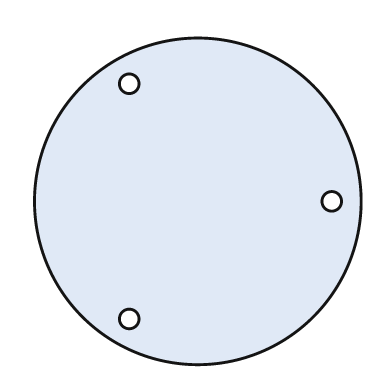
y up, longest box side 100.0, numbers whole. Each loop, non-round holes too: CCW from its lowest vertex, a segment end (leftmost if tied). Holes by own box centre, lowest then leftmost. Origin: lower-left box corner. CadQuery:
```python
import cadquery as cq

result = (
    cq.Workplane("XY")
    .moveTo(50.0, 50.0)
    .circle(50.0)
    .moveTo(29.0, 14.0)
    .circle(3.0)
    .moveTo(91.0, 50.0)
    .circle(3.0)
    .moveTo(29.0, 86.0)
    .circle(3.0)
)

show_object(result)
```